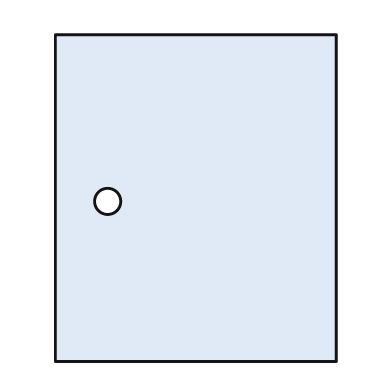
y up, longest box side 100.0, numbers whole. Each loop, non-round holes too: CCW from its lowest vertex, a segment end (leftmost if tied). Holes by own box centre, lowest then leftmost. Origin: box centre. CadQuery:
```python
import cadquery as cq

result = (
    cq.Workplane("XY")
    .moveTo(-43.0, -50.0)
    .lineTo(43.0, -50.0)
    .lineTo(43.0, 50.0)
    .lineTo(-43.0, 50.0)
    .close()
    .moveTo(-27.0, -1.0)
    .circle(4.0)
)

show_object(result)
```